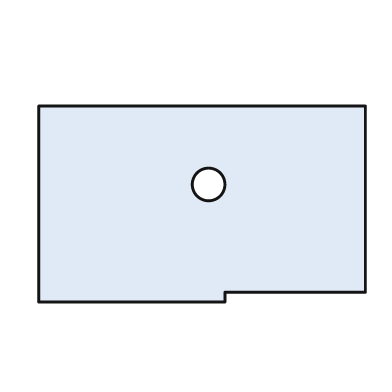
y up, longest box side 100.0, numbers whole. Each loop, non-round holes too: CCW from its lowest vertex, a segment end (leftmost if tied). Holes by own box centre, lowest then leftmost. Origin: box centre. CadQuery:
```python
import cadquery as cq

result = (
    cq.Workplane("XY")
    .moveTo(-50.0, -30.0)
    .lineTo(7.0, -30.0)
    .lineTo(7.0, -27.0)
    .lineTo(50.0, -27.0)
    .lineTo(50.0, 30.0)
    .lineTo(-50.0, 30.0)
    .close()
    .moveTo(2.0, 6.0)
    .circle(5.0)
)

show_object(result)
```